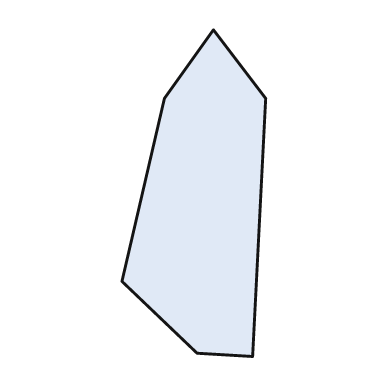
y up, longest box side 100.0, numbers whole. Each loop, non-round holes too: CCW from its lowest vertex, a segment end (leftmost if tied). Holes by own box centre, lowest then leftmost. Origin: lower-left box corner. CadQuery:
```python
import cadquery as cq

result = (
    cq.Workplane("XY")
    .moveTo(40.0, 0.0)
    .lineTo(44.0, 79.0)
    .lineTo(28.0, 100.0)
    .lineTo(13.0, 79.0)
    .lineTo(0.0, 23.0)
    .lineTo(23.0, 1.0)
    .close()
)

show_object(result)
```